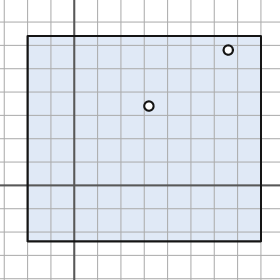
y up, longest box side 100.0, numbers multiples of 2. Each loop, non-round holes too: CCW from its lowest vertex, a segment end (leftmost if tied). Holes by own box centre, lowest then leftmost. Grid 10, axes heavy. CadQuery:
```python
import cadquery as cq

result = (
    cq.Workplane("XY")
    .moveTo(-20.0, -24.0)
    .lineTo(80.0, -24.0)
    .lineTo(80.0, 64.0)
    .lineTo(-20.0, 64.0)
    .close()
    .moveTo(32.0, 34.0)
    .circle(2.0)
    .moveTo(66.0, 58.0)
    .circle(2.0)
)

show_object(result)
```